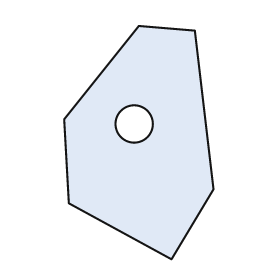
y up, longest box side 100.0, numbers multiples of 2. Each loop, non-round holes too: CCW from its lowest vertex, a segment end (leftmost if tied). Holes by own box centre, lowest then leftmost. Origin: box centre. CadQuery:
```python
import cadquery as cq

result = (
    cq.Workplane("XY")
    .moveTo(14.0, -50.0)
    .lineTo(32.0, -20.0)
    .lineTo(24.0, 48.0)
    .lineTo(0.0, 50.0)
    .lineTo(-32.0, 10.0)
    .lineTo(-30.0, -26.0)
    .close()
    .moveTo(-2.0, 8.0)
    .circle(8.0)
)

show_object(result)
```